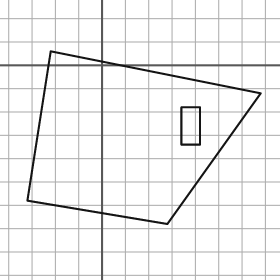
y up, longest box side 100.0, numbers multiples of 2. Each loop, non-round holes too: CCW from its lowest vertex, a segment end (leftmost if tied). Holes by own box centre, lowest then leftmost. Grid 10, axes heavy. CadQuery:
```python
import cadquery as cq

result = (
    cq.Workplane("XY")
    .moveTo(28.0, -68.0)
    .lineTo(68.0, -12.0)
    .lineTo(-22.0, 6.0)
    .lineTo(-32.0, -58.0)
    .close()
    .moveTo(34.0, -34.0)
    .lineTo(42.0, -34.0)
    .lineTo(42.0, -18.0)
    .lineTo(34.0, -18.0)
    .close()
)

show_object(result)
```